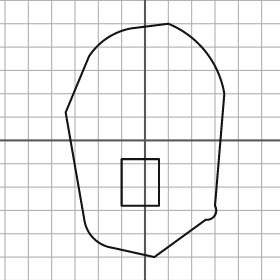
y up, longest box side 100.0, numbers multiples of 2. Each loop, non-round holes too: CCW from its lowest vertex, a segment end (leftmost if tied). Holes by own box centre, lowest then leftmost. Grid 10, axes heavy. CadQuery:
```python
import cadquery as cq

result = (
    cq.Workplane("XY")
    .moveTo(4.0, -50.0)
    .lineTo(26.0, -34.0)
    .threePointArc((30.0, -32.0), (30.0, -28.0))
    .lineTo(34.0, 20.0)
    .threePointArc((26.0, 38.0), (10.0, 50.0))
    .lineTo(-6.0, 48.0)
    .threePointArc((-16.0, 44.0), (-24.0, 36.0))
    .lineTo(-34.0, 12.0)
    .lineTo(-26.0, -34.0)
    .threePointArc((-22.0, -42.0), (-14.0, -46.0))
    .close()
    .moveTo(-10.0, -28.0)
    .lineTo(6.0, -28.0)
    .lineTo(6.0, -8.0)
    .lineTo(-10.0, -8.0)
    .close()
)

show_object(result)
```